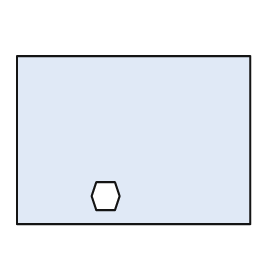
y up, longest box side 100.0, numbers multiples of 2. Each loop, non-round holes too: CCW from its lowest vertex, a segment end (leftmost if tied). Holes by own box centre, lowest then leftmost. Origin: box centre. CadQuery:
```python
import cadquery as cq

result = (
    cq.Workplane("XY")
    .moveTo(-50.0, -36.0)
    .lineTo(50.0, -36.0)
    .lineTo(50.0, 36.0)
    .lineTo(-50.0, 36.0)
    .close()
    .moveTo(-16.0, -30.0)
    .lineTo(-8.0, -30.0)
    .lineTo(-6.0, -24.0)
    .lineTo(-8.0, -18.0)
    .lineTo(-16.0, -18.0)
    .lineTo(-18.0, -24.0)
    .close()
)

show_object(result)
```